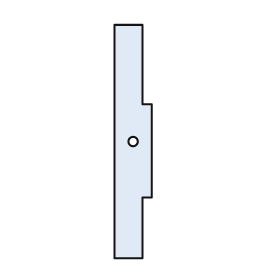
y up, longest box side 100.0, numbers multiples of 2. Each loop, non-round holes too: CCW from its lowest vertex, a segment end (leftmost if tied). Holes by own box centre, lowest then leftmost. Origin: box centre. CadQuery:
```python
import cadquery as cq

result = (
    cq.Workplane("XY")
    .moveTo(-8.0, -50.0)
    .lineTo(4.0, -50.0)
    .lineTo(4.0, -24.0)
    .lineTo(8.0, -24.0)
    .lineTo(8.0, 16.0)
    .lineTo(4.0, 16.0)
    .lineTo(4.0, 50.0)
    .lineTo(-8.0, 50.0)
    .close()
    .moveTo(0.0, 0.0)
    .circle(2.0)
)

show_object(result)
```